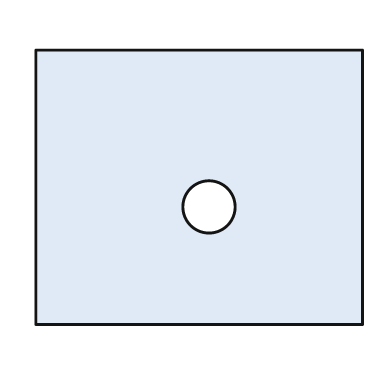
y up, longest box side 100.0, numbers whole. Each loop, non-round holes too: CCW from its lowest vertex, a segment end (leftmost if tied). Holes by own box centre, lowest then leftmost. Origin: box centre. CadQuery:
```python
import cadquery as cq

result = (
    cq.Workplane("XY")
    .moveTo(-50.0, -42.0)
    .lineTo(50.0, -42.0)
    .lineTo(50.0, 42.0)
    .lineTo(-50.0, 42.0)
    .close()
    .moveTo(3.0, -6.0)
    .circle(8.0)
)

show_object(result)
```